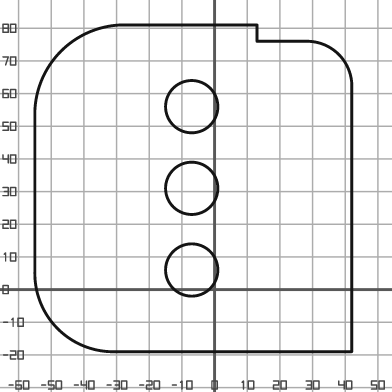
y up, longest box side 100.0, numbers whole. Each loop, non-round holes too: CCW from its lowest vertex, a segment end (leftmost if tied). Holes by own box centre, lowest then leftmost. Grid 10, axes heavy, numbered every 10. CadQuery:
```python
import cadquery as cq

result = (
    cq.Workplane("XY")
    .moveTo(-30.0, -19.0)
    .lineTo(42.0, -19.0)
    .lineTo(42.0, 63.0)
    .threePointArc((38.0, 72.0), (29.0, 76.0))
    .lineTo(13.0, 76.0)
    .lineTo(13.0, 81.0)
    .lineTo(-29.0, 81.0)
    .threePointArc((-47.0, 73.0), (-55.0, 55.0))
    .lineTo(-55.0, 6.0)
    .threePointArc((-48.0, -12.0), (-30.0, -19.0))
    .close()
    .moveTo(-7.0, 6.0)
    .circle(8.0)
    .moveTo(-7.0, 31.0)
    .circle(8.0)
    .moveTo(-7.0, 56.0)
    .circle(8.0)
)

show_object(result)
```